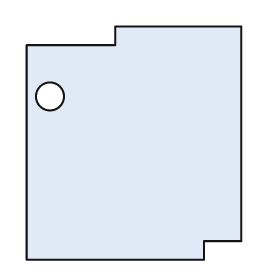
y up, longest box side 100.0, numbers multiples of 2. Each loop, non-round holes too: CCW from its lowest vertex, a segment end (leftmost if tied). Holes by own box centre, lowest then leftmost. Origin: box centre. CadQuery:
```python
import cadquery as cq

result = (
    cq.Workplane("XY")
    .moveTo(-46.0, -50.0)
    .lineTo(30.0, -50.0)
    .lineTo(30.0, -42.0)
    .lineTo(46.0, -42.0)
    .lineTo(46.0, 50.0)
    .lineTo(-8.0, 50.0)
    .lineTo(-8.0, 42.0)
    .lineTo(-46.0, 42.0)
    .close()
    .moveTo(-36.0, 20.0)
    .circle(6.0)
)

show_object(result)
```